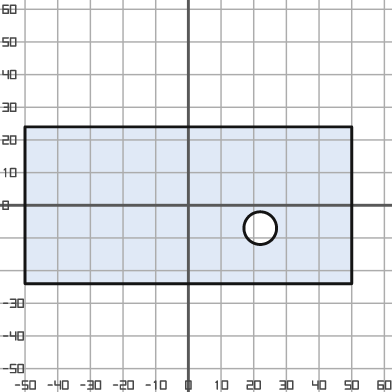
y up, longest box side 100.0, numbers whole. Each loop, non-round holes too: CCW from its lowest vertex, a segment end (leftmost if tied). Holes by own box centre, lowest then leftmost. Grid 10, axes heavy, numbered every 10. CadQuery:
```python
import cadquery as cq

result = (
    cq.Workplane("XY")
    .moveTo(-50.0, -24.0)
    .lineTo(50.0, -24.0)
    .lineTo(50.0, 24.0)
    .lineTo(-50.0, 24.0)
    .close()
    .moveTo(22.0, -7.0)
    .circle(5.0)
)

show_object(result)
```